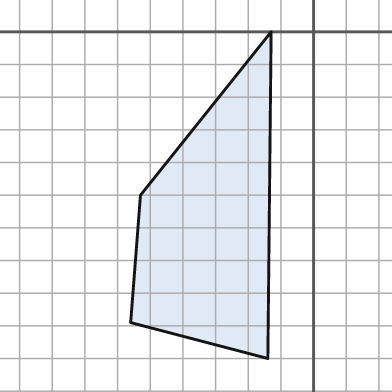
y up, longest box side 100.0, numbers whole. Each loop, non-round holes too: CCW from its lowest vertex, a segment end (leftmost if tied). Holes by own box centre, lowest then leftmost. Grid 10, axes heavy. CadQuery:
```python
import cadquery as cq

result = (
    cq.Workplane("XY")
    .moveTo(-14.0, -100.0)
    .lineTo(-13.0, 0.0)
    .lineTo(-53.0, -50.0)
    .lineTo(-56.0, -89.0)
    .close()
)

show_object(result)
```